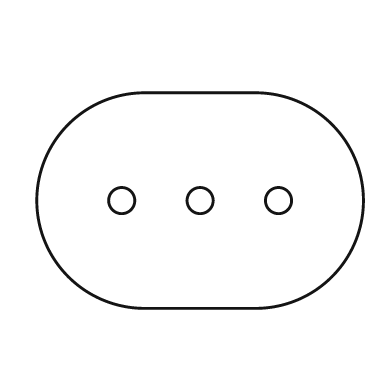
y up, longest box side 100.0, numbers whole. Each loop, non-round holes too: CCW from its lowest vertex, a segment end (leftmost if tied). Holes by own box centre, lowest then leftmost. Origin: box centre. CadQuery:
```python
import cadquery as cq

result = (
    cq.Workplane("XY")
    .moveTo(-17.0, -33.0)
    .lineTo(17.0, -33.0)
    .threePointArc((50.0, 0.0), (17.0, 33.0))
    .lineTo(-17.0, 33.0)
    .threePointArc((-50.0, 0.0), (-17.0, -33.0))
    .close()
    .moveTo(-24.0, 0.0)
    .circle(4.0)
    .moveTo(0.0, 0.0)
    .circle(4.0)
    .moveTo(24.0, 0.0)
    .circle(4.0)
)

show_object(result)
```